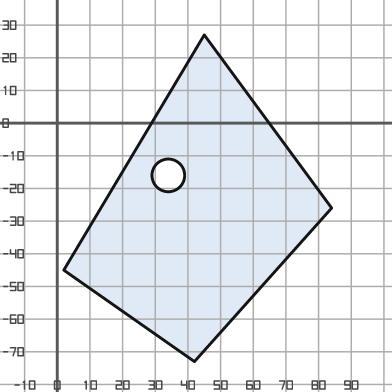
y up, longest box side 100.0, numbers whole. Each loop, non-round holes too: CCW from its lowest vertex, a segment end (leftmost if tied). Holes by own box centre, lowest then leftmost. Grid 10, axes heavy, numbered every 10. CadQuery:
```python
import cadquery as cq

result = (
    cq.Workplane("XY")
    .moveTo(42.0, -73.0)
    .lineTo(84.0, -26.0)
    .lineTo(45.0, 27.0)
    .lineTo(2.0, -45.0)
    .close()
    .moveTo(34.0, -16.0)
    .circle(5.0)
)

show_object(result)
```